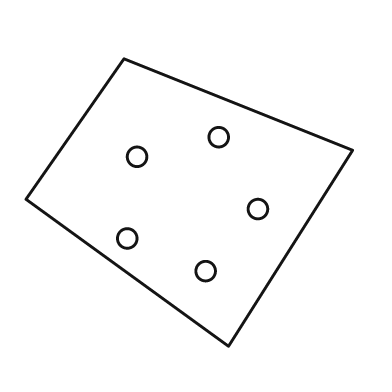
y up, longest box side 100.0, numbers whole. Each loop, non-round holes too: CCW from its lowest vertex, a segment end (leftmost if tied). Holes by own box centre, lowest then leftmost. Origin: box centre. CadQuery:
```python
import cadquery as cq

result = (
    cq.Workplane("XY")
    .moveTo(12.0, -44.0)
    .lineTo(50.0, 16.0)
    .lineTo(-20.0, 44.0)
    .lineTo(-50.0, 1.0)
    .close()
    .moveTo(5.0, -21.0)
    .circle(3.0)
    .moveTo(-19.0, -11.0)
    .circle(3.0)
    .moveTo(21.0, -2.0)
    .circle(3.0)
    .moveTo(-16.0, 14.0)
    .circle(3.0)
    .moveTo(9.0, 20.0)
    .circle(3.0)
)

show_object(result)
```